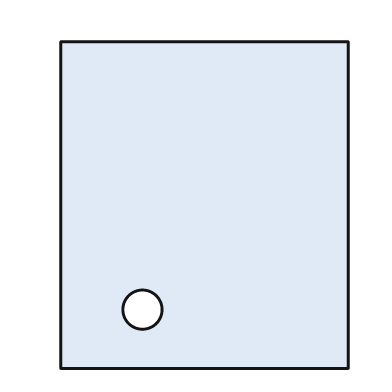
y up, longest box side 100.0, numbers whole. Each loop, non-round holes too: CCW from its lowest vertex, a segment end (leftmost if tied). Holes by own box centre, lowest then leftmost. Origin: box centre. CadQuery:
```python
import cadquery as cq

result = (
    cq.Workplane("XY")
    .moveTo(-44.0, -50.0)
    .lineTo(44.0, -50.0)
    .lineTo(44.0, 50.0)
    .lineTo(-44.0, 50.0)
    .close()
    .moveTo(-19.0, -32.0)
    .circle(6.0)
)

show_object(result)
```